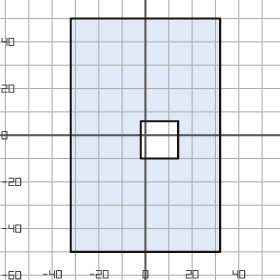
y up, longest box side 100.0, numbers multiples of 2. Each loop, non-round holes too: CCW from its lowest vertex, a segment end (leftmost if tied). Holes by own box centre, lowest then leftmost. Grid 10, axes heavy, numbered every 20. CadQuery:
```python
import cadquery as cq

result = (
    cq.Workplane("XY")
    .moveTo(-32.0, -50.0)
    .lineTo(32.0, -50.0)
    .lineTo(32.0, 50.0)
    .lineTo(-32.0, 50.0)
    .close()
    .moveTo(-2.0, -10.0)
    .lineTo(14.0, -10.0)
    .lineTo(14.0, 6.0)
    .lineTo(-2.0, 6.0)
    .close()
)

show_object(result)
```